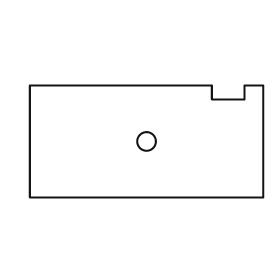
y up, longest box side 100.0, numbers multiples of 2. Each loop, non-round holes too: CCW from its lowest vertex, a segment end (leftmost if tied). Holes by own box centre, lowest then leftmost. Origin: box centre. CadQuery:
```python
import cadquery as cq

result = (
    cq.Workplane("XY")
    .moveTo(-50.0, -24.0)
    .lineTo(50.0, -24.0)
    .lineTo(50.0, 24.0)
    .lineTo(42.0, 24.0)
    .lineTo(42.0, 18.0)
    .lineTo(28.0, 18.0)
    .lineTo(28.0, 24.0)
    .lineTo(-50.0, 24.0)
    .close()
    .moveTo(0.0, 0.0)
    .circle(4.0)
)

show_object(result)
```